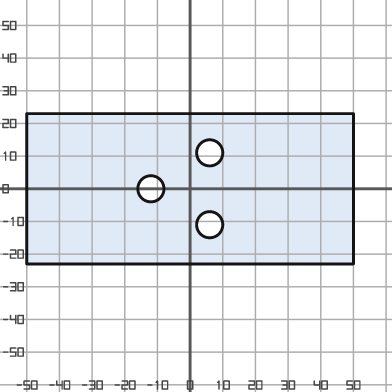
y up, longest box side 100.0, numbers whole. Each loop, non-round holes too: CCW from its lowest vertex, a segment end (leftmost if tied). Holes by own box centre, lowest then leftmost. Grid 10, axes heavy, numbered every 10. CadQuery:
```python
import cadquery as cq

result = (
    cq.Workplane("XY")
    .moveTo(-50.0, -23.0)
    .lineTo(50.0, -23.0)
    .lineTo(50.0, 23.0)
    .lineTo(-50.0, 23.0)
    .close()
    .moveTo(6.0, -11.0)
    .circle(4.0)
    .moveTo(-12.0, 0.0)
    .circle(4.0)
    .moveTo(6.0, 11.0)
    .circle(4.0)
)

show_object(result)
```